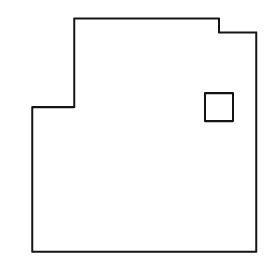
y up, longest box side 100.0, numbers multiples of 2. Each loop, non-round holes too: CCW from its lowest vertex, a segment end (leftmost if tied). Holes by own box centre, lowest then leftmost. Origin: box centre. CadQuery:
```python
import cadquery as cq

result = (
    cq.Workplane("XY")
    .moveTo(-48.0, -50.0)
    .lineTo(48.0, -50.0)
    .lineTo(48.0, 44.0)
    .lineTo(32.0, 44.0)
    .lineTo(32.0, 50.0)
    .lineTo(-30.0, 50.0)
    .lineTo(-30.0, 12.0)
    .lineTo(-48.0, 12.0)
    .close()
    .moveTo(26.0, 6.0)
    .lineTo(38.0, 6.0)
    .lineTo(38.0, 18.0)
    .lineTo(26.0, 18.0)
    .close()
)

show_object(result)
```